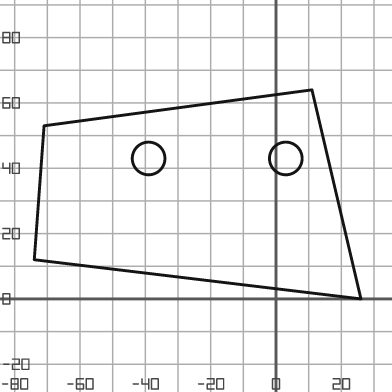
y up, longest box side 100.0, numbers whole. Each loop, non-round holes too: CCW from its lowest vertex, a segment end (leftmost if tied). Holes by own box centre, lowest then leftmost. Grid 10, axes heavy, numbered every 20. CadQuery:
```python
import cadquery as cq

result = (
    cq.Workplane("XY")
    .moveTo(26.0, 0.0)
    .lineTo(11.0, 64.0)
    .lineTo(-71.0, 53.0)
    .lineTo(-74.0, 12.0)
    .close()
    .moveTo(-39.0, 43.0)
    .circle(5.0)
    .moveTo(3.0, 43.0)
    .circle(5.0)
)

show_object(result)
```